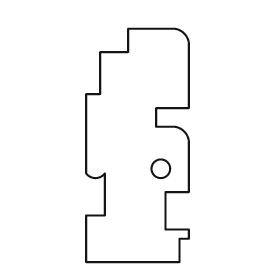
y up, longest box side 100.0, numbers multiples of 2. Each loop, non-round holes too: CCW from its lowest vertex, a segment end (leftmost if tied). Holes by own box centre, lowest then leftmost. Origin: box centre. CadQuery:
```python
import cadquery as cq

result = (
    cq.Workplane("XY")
    .moveTo(-22.0, -50.0)
    .lineTo(18.0, -50.0)
    .lineTo(18.0, -40.0)
    .lineTo(22.0, -40.0)
    .lineTo(22.0, -36.0)
    .lineTo(12.0, -36.0)
    .lineTo(12.0, -20.0)
    .lineTo(22.0, -20.0)
    .lineTo(22.0, 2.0)
    .threePointArc((20.0, 6.0), (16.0, 8.0))
    .lineTo(8.0, 8.0)
    .lineTo(8.0, 16.0)
    .lineTo(22.0, 16.0)
    .lineTo(22.0, 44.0)
    .threePointArc((20.0, 48.0), (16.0, 50.0))
    .lineTo(-4.0, 50.0)
    .lineTo(-4.0, 40.0)
    .lineTo(-16.0, 40.0)
    .lineTo(-16.0, 22.0)
    .lineTo(-22.0, 22.0)
    .lineTo(-22.0, -12.0)
    .threePointArc((-18.0, -14.0), (-14.0, -12.0))
    .lineTo(-14.0, -30.0)
    .lineTo(-22.0, -30.0)
    .close()
    .moveTo(10.0, -10.0)
    .circle(4.0)
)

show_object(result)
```